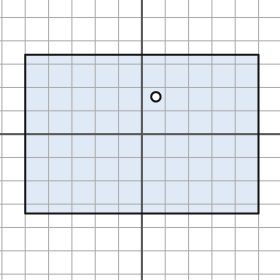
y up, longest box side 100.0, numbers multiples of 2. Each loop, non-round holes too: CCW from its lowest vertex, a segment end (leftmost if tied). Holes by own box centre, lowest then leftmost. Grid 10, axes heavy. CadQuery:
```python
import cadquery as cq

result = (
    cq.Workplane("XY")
    .moveTo(-50.0, -34.0)
    .lineTo(50.0, -34.0)
    .lineTo(50.0, 34.0)
    .lineTo(-50.0, 34.0)
    .close()
    .moveTo(6.0, 16.0)
    .circle(2.0)
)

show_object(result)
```